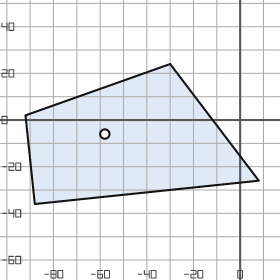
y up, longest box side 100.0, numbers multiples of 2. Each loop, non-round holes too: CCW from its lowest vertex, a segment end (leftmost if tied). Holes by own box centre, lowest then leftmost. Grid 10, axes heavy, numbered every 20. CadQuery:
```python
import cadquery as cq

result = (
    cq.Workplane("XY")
    .moveTo(-88.0, -36.0)
    .lineTo(8.0, -26.0)
    .lineTo(-30.0, 24.0)
    .lineTo(-92.0, 2.0)
    .close()
    .moveTo(-58.0, -6.0)
    .circle(2.0)
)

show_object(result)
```